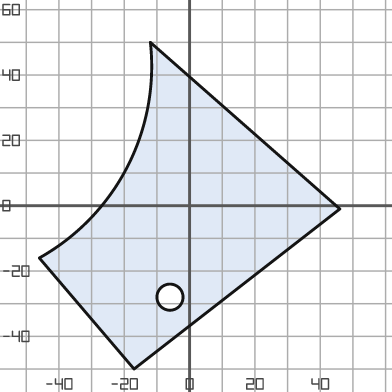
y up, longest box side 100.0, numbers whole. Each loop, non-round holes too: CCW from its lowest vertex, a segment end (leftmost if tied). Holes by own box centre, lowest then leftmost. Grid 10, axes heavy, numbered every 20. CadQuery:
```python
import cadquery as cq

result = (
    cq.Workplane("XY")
    .moveTo(-17.0, -50.0)
    .lineTo(46.0, -1.0)
    .lineTo(-12.0, 50.0)
    .threePointArc((-19.0, 12.0), (-46.0, -16.0))
    .close()
    .moveTo(-6.0, -28.0)
    .circle(4.0)
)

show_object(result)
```